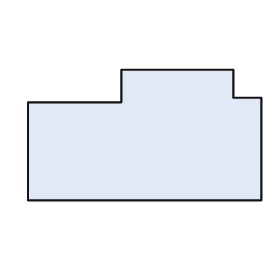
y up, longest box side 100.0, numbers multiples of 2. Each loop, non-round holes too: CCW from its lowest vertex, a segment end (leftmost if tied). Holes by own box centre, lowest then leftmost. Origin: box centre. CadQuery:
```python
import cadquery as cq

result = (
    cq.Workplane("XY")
    .moveTo(-50.0, -28.0)
    .lineTo(50.0, -28.0)
    .lineTo(50.0, 16.0)
    .lineTo(38.0, 16.0)
    .lineTo(38.0, 28.0)
    .lineTo(-10.0, 28.0)
    .lineTo(-10.0, 14.0)
    .lineTo(-50.0, 14.0)
    .close()
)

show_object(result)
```